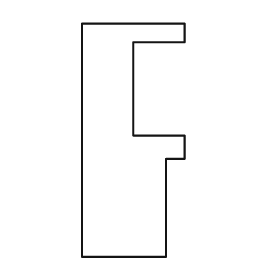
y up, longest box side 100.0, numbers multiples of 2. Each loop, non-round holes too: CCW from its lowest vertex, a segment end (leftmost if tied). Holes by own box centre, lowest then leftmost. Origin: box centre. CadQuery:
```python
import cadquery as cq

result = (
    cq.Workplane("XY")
    .moveTo(-22.0, -50.0)
    .lineTo(14.0, -50.0)
    .lineTo(14.0, -8.0)
    .lineTo(22.0, -8.0)
    .lineTo(22.0, 2.0)
    .lineTo(0.0, 2.0)
    .lineTo(0.0, 42.0)
    .lineTo(22.0, 42.0)
    .lineTo(22.0, 50.0)
    .lineTo(-22.0, 50.0)
    .close()
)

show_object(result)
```